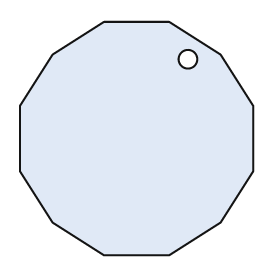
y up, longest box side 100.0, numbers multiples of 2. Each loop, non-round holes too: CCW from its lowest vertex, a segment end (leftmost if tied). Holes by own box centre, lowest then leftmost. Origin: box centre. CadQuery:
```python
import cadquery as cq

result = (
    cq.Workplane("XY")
    .moveTo(-14.0, -50.0)
    .lineTo(14.0, -50.0)
    .lineTo(36.0, -36.0)
    .lineTo(50.0, -14.0)
    .lineTo(50.0, 14.0)
    .lineTo(36.0, 36.0)
    .lineTo(14.0, 50.0)
    .lineTo(-14.0, 50.0)
    .lineTo(-36.0, 36.0)
    .lineTo(-50.0, 14.0)
    .lineTo(-50.0, -14.0)
    .lineTo(-36.0, -36.0)
    .close()
    .moveTo(22.0, 34.0)
    .circle(4.0)
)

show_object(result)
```